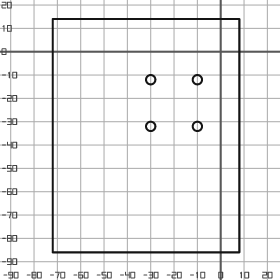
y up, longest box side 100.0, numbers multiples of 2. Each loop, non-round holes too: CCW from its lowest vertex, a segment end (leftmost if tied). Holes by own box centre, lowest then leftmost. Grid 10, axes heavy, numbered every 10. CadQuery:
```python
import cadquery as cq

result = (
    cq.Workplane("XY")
    .moveTo(-72.0, -86.0)
    .lineTo(8.0, -86.0)
    .lineTo(8.0, 14.0)
    .lineTo(-72.0, 14.0)
    .close()
    .moveTo(-30.0, -32.0)
    .circle(2.0)
    .moveTo(-10.0, -32.0)
    .circle(2.0)
    .moveTo(-30.0, -12.0)
    .circle(2.0)
    .moveTo(-10.0, -12.0)
    .circle(2.0)
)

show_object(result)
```